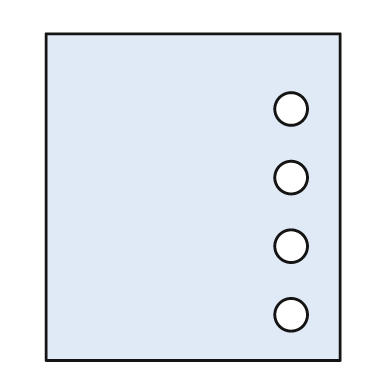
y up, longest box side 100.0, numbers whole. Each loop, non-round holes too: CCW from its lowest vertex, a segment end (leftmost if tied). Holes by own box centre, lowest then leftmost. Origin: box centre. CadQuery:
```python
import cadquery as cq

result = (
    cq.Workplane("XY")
    .moveTo(-45.0, -50.0)
    .lineTo(45.0, -50.0)
    .lineTo(45.0, 50.0)
    .lineTo(-45.0, 50.0)
    .close()
    .moveTo(30.0, -36.0)
    .circle(5.0)
    .moveTo(30.0, -15.0)
    .circle(5.0)
    .moveTo(30.0, 6.0)
    .circle(5.0)
    .moveTo(30.0, 27.0)
    .circle(5.0)
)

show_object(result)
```